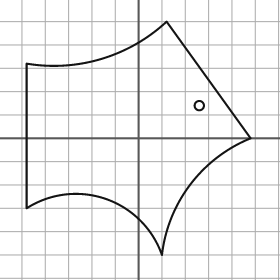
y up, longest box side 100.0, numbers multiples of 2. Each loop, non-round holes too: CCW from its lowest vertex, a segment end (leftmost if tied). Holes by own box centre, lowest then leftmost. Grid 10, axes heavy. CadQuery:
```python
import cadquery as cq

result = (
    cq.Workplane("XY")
    .moveTo(10.0, -50.0)
    .threePointArc((22.0, -20.0), (48.0, 0.0))
    .lineTo(12.0, 50.0)
    .threePointArc((-16.0, 34.0), (-48.0, 32.0))
    .lineTo(-48.0, -30.0)
    .threePointArc((-14.0, -26.0), (10.0, -50.0))
    .close()
    .moveTo(26.0, 14.0)
    .circle(2.0)
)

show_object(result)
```